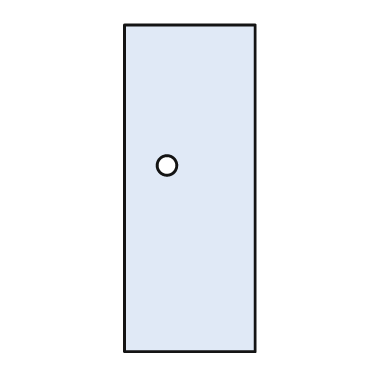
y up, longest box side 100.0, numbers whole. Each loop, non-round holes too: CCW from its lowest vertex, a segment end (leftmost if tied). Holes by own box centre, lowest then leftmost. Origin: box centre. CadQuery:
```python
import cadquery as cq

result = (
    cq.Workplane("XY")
    .moveTo(-20.0, -50.0)
    .lineTo(20.0, -50.0)
    .lineTo(20.0, 50.0)
    .lineTo(-20.0, 50.0)
    .close()
    .moveTo(-7.0, 7.0)
    .circle(3.0)
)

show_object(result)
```